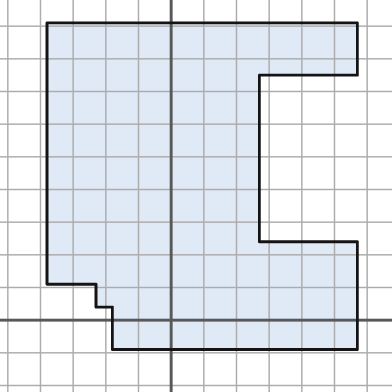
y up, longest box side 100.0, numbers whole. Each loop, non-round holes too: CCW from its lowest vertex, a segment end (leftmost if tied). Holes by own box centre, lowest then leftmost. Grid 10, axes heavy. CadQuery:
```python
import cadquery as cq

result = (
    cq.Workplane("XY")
    .moveTo(-18.0, -9.0)
    .lineTo(57.0, -9.0)
    .lineTo(57.0, 24.0)
    .lineTo(27.0, 24.0)
    .lineTo(27.0, 75.0)
    .lineTo(57.0, 75.0)
    .lineTo(57.0, 91.0)
    .lineTo(-38.0, 91.0)
    .lineTo(-38.0, 11.0)
    .lineTo(-23.0, 11.0)
    .lineTo(-23.0, 4.0)
    .lineTo(-18.0, 4.0)
    .close()
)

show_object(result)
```